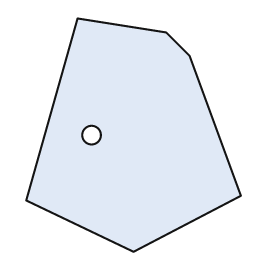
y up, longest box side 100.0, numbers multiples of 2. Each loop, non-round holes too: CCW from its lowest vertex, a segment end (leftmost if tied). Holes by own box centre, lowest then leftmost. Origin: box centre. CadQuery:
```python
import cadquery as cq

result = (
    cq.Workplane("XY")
    .moveTo(0.0, -50.0)
    .lineTo(46.0, -26.0)
    .lineTo(24.0, 34.0)
    .lineTo(14.0, 44.0)
    .lineTo(-24.0, 50.0)
    .lineTo(-46.0, -28.0)
    .close()
    .moveTo(-18.0, 0.0)
    .circle(4.0)
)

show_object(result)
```